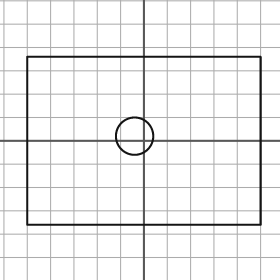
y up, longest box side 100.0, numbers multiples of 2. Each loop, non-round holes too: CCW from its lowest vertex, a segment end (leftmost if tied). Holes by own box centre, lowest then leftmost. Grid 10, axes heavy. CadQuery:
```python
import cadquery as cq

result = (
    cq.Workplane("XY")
    .moveTo(-50.0, -36.0)
    .lineTo(50.0, -36.0)
    .lineTo(50.0, 36.0)
    .lineTo(-50.0, 36.0)
    .close()
    .moveTo(-4.0, 2.0)
    .circle(8.0)
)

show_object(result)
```